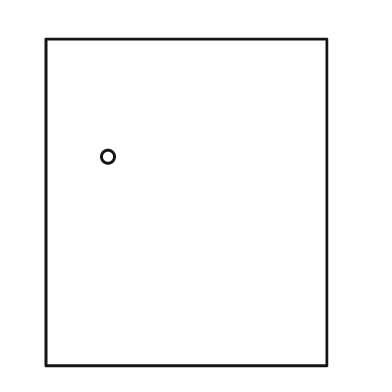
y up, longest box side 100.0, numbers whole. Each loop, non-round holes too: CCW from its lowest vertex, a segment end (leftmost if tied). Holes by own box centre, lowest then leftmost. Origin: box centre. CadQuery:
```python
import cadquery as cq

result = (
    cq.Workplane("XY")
    .moveTo(-43.0, -50.0)
    .lineTo(43.0, -50.0)
    .lineTo(43.0, 50.0)
    .lineTo(-43.0, 50.0)
    .close()
    .moveTo(-24.0, 14.0)
    .circle(2.0)
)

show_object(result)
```